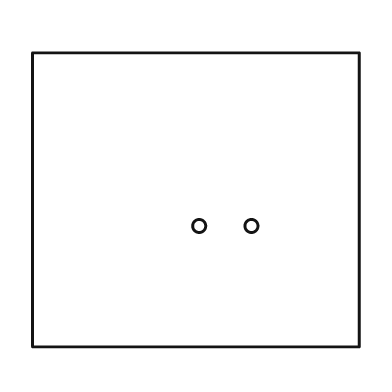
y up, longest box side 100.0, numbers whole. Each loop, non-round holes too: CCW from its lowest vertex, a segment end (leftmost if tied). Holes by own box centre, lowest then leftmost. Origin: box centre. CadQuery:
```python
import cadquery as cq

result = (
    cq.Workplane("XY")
    .moveTo(-50.0, -45.0)
    .lineTo(50.0, -45.0)
    .lineTo(50.0, 45.0)
    .lineTo(-50.0, 45.0)
    .close()
    .moveTo(1.0, -8.0)
    .circle(2.0)
    .moveTo(17.0, -8.0)
    .circle(2.0)
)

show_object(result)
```